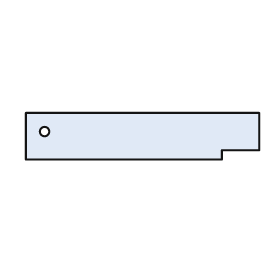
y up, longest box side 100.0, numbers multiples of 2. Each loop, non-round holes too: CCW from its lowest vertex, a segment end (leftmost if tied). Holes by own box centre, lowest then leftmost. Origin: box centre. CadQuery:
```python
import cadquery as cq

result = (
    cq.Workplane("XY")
    .moveTo(-50.0, -10.0)
    .lineTo(34.0, -10.0)
    .lineTo(34.0, -6.0)
    .lineTo(50.0, -6.0)
    .lineTo(50.0, 10.0)
    .lineTo(-50.0, 10.0)
    .close()
    .moveTo(-42.0, 2.0)
    .circle(2.0)
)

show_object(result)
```